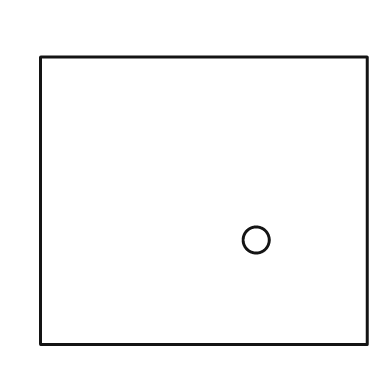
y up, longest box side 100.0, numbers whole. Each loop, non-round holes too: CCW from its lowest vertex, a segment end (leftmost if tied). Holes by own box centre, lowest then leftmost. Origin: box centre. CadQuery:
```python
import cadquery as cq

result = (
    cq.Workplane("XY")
    .moveTo(-50.0, -44.0)
    .lineTo(50.0, -44.0)
    .lineTo(50.0, 44.0)
    .lineTo(-50.0, 44.0)
    .close()
    .moveTo(16.0, -12.0)
    .circle(4.0)
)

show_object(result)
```